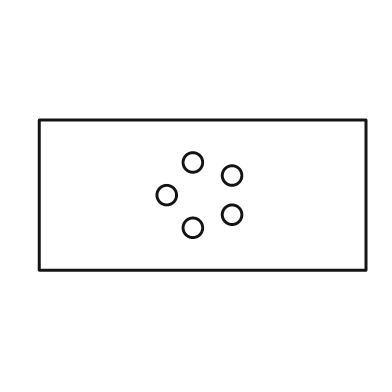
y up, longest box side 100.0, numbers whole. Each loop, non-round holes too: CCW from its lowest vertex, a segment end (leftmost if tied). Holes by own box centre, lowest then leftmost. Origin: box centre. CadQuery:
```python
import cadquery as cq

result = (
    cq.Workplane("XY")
    .moveTo(-50.0, -23.0)
    .lineTo(50.0, -23.0)
    .lineTo(50.0, 23.0)
    .lineTo(-50.0, 23.0)
    .close()
    .moveTo(-3.0, -10.0)
    .circle(3.0)
    .moveTo(9.0, -6.0)
    .circle(3.0)
    .moveTo(-11.0, 0.0)
    .circle(3.0)
    .moveTo(9.0, 6.0)
    .circle(3.0)
    .moveTo(-3.0, 10.0)
    .circle(3.0)
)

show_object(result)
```